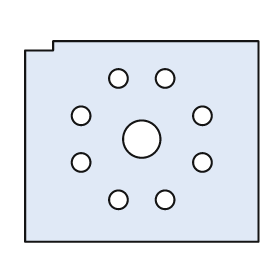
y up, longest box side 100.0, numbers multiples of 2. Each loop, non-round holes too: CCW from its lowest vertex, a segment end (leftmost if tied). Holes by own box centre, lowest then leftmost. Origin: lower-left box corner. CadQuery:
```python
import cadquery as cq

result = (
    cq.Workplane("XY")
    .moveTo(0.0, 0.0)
    .lineTo(100.0, 0.0)
    .lineTo(100.0, 86.0)
    .lineTo(12.0, 86.0)
    .lineTo(12.0, 82.0)
    .lineTo(0.0, 82.0)
    .close()
    .moveTo(40.0, 18.0)
    .circle(4.0)
    .moveTo(60.0, 18.0)
    .circle(4.0)
    .moveTo(24.0, 34.0)
    .circle(4.0)
    .moveTo(76.0, 34.0)
    .circle(4.0)
    .moveTo(50.0, 44.0)
    .circle(8.0)
    .moveTo(24.0, 54.0)
    .circle(4.0)
    .moveTo(76.0, 54.0)
    .circle(4.0)
    .moveTo(40.0, 70.0)
    .circle(4.0)
    .moveTo(60.0, 70.0)
    .circle(4.0)
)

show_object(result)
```